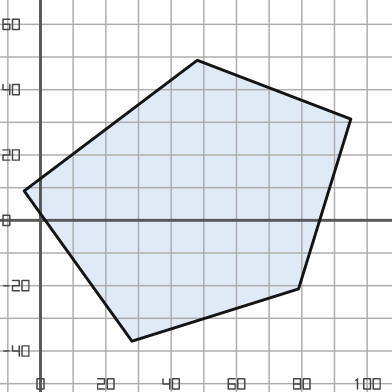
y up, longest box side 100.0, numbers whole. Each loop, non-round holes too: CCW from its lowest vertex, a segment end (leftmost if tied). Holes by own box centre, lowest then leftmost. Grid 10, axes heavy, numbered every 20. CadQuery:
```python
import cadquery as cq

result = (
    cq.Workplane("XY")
    .moveTo(28.0, -37.0)
    .lineTo(79.0, -21.0)
    .lineTo(95.0, 31.0)
    .lineTo(48.0, 49.0)
    .lineTo(-5.0, 9.0)
    .close()
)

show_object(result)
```